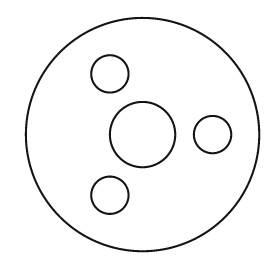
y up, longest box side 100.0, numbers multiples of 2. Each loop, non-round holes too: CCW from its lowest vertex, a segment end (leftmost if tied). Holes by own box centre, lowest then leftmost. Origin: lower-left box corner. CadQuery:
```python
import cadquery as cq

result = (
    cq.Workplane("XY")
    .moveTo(50.0, 50.0)
    .circle(50.0)
    .moveTo(36.0, 24.0)
    .circle(8.0)
    .moveTo(50.0, 50.0)
    .circle(14.0)
    .moveTo(80.0, 50.0)
    .circle(8.0)
    .moveTo(36.0, 76.0)
    .circle(8.0)
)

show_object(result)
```